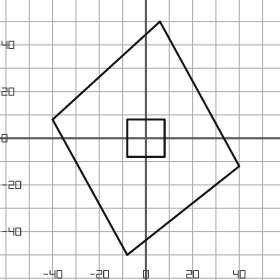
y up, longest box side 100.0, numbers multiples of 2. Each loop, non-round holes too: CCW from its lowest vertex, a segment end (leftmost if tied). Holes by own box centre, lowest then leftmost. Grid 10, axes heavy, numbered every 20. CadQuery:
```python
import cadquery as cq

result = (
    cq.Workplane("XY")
    .moveTo(-8.0, -50.0)
    .lineTo(40.0, -12.0)
    .lineTo(6.0, 50.0)
    .lineTo(-40.0, 8.0)
    .close()
    .moveTo(-8.0, -8.0)
    .lineTo(8.0, -8.0)
    .lineTo(8.0, 8.0)
    .lineTo(-8.0, 8.0)
    .close()
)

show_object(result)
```